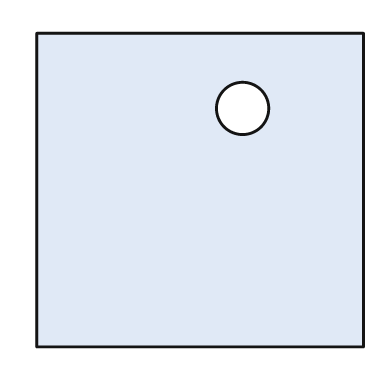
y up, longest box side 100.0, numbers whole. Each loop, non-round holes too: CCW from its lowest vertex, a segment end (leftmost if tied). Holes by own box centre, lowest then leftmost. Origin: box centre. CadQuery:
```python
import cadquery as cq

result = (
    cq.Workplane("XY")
    .moveTo(-50.0, -48.0)
    .lineTo(50.0, -48.0)
    .lineTo(50.0, 48.0)
    .lineTo(-50.0, 48.0)
    .close()
    .moveTo(13.0, 25.0)
    .circle(8.0)
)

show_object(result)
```